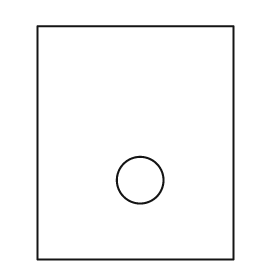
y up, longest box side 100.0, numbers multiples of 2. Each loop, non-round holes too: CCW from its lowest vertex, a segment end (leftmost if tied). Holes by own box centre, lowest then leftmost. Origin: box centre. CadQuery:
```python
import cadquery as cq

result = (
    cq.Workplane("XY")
    .moveTo(-42.0, -50.0)
    .lineTo(42.0, -50.0)
    .lineTo(42.0, 50.0)
    .lineTo(-42.0, 50.0)
    .close()
    .moveTo(2.0, -16.0)
    .circle(10.0)
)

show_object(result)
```